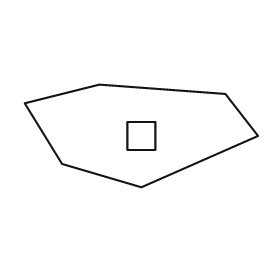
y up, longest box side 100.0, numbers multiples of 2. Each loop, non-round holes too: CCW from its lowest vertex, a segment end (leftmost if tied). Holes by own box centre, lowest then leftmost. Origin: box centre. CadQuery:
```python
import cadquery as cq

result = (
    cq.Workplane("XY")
    .moveTo(0.0, -22.0)
    .lineTo(50.0, 0.0)
    .lineTo(36.0, 18.0)
    .lineTo(-18.0, 22.0)
    .lineTo(-50.0, 14.0)
    .lineTo(-34.0, -12.0)
    .close()
    .moveTo(-6.0, -6.0)
    .lineTo(6.0, -6.0)
    .lineTo(6.0, 6.0)
    .lineTo(-6.0, 6.0)
    .close()
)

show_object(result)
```